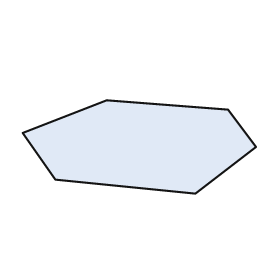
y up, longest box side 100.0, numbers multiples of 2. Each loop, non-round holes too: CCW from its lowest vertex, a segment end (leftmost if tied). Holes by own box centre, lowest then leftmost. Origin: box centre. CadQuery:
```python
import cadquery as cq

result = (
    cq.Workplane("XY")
    .moveTo(24.0, -20.0)
    .lineTo(50.0, 0.0)
    .lineTo(38.0, 16.0)
    .lineTo(-14.0, 20.0)
    .lineTo(-50.0, 6.0)
    .lineTo(-36.0, -14.0)
    .close()
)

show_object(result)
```